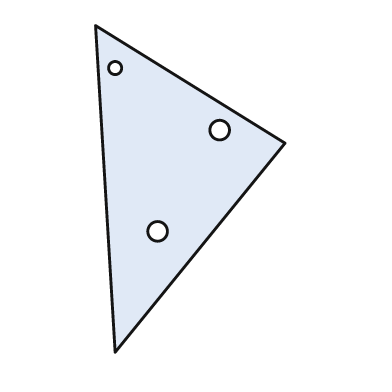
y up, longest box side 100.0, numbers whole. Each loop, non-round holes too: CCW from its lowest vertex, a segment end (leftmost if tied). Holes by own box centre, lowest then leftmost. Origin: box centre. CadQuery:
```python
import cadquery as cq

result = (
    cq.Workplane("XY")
    .moveTo(-23.0, -50.0)
    .lineTo(29.0, 14.0)
    .lineTo(-29.0, 50.0)
    .close()
    .moveTo(-10.0, -13.0)
    .circle(3.0)
    .moveTo(9.0, 18.0)
    .circle(3.0)
    .moveTo(-23.0, 37.0)
    .circle(2.0)
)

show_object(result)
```